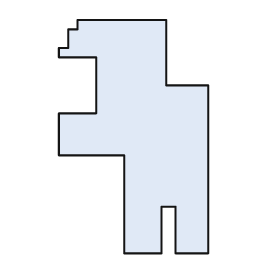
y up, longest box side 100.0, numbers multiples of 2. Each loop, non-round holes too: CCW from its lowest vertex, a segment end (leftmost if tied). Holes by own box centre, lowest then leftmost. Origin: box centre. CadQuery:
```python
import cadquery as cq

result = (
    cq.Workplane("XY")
    .moveTo(-4.0, -50.0)
    .lineTo(12.0, -50.0)
    .lineTo(12.0, -30.0)
    .lineTo(18.0, -30.0)
    .lineTo(18.0, -50.0)
    .lineTo(32.0, -50.0)
    .lineTo(32.0, 22.0)
    .lineTo(14.0, 22.0)
    .lineTo(14.0, 50.0)
    .lineTo(-24.0, 50.0)
    .lineTo(-24.0, 46.0)
    .lineTo(-28.0, 46.0)
    .lineTo(-28.0, 38.0)
    .lineTo(-32.0, 38.0)
    .lineTo(-32.0, 34.0)
    .lineTo(-16.0, 34.0)
    .lineTo(-16.0, 10.0)
    .lineTo(-32.0, 10.0)
    .lineTo(-32.0, -8.0)
    .lineTo(-4.0, -8.0)
    .close()
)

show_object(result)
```